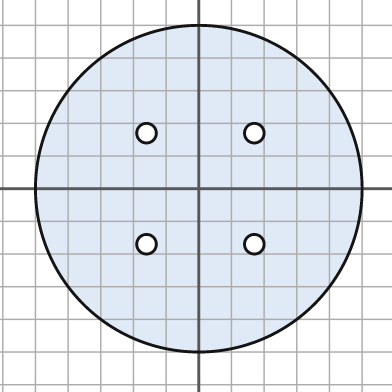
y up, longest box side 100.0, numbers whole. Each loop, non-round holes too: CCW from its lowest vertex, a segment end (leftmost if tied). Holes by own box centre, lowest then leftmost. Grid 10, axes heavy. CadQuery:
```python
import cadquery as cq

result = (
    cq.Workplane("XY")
    .moveTo(0.0, 0.0)
    .circle(50.0)
    .moveTo(-16.0, -17.0)
    .circle(3.0)
    .moveTo(17.0, -17.0)
    .circle(3.0)
    .moveTo(-16.0, 17.0)
    .circle(3.0)
    .moveTo(17.0, 17.0)
    .circle(3.0)
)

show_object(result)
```